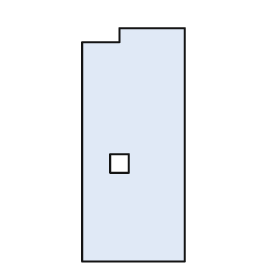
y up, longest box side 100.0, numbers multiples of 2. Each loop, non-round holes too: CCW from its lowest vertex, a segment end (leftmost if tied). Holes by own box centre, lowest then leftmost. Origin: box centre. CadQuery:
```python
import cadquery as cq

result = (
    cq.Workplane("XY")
    .moveTo(-22.0, -50.0)
    .lineTo(22.0, -50.0)
    .lineTo(22.0, 50.0)
    .lineTo(-6.0, 50.0)
    .lineTo(-6.0, 44.0)
    .lineTo(-22.0, 44.0)
    .close()
    .moveTo(-10.0, -12.0)
    .lineTo(-2.0, -12.0)
    .lineTo(-2.0, -4.0)
    .lineTo(-10.0, -4.0)
    .close()
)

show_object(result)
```